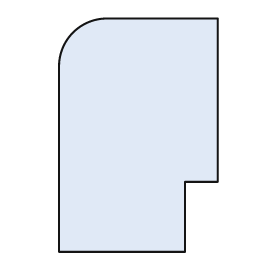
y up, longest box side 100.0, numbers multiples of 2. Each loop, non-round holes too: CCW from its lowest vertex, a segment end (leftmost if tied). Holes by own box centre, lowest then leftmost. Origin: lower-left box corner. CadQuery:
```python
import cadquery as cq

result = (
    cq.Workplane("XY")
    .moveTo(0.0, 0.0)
    .lineTo(54.0, 0.0)
    .lineTo(54.0, 30.0)
    .lineTo(68.0, 30.0)
    .lineTo(68.0, 100.0)
    .lineTo(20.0, 100.0)
    .threePointArc((6.0, 94.0), (0.0, 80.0))
    .close()
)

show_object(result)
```